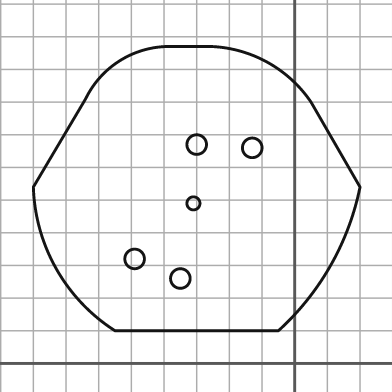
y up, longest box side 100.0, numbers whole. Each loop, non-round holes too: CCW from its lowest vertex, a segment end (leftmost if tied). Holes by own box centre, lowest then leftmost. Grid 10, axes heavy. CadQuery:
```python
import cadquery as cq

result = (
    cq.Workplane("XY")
    .moveTo(-55.0, 10.0)
    .lineTo(-5.0, 10.0)
    .threePointArc((11.0, 30.0), (20.0, 54.0))
    .lineTo(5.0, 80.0)
    .threePointArc((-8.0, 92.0), (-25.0, 97.0))
    .lineTo(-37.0, 97.0)
    .threePointArc((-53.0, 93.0), (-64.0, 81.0))
    .lineTo(-80.0, 54.0)
    .threePointArc((-73.0, 29.0), (-55.0, 10.0))
    .close()
    .moveTo(-35.0, 26.0)
    .circle(3.0)
    .moveTo(-49.0, 32.0)
    .circle(3.0)
    .moveTo(-31.0, 49.0)
    .circle(2.0)
    .moveTo(-13.0, 66.0)
    .circle(3.0)
    .moveTo(-30.0, 67.0)
    .circle(3.0)
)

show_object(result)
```